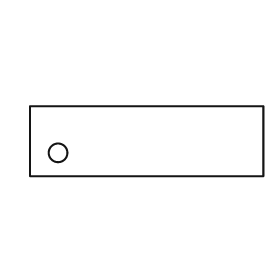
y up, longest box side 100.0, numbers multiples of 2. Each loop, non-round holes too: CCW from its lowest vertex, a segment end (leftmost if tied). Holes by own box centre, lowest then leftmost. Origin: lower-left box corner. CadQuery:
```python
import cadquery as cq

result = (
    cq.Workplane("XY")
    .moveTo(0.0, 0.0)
    .lineTo(100.0, 0.0)
    .lineTo(100.0, 30.0)
    .lineTo(0.0, 30.0)
    .close()
    .moveTo(12.0, 10.0)
    .circle(4.0)
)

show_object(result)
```